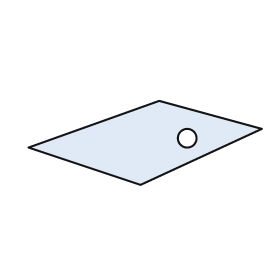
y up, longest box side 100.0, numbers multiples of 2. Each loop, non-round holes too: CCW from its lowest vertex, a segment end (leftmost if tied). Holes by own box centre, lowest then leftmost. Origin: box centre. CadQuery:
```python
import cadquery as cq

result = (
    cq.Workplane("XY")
    .moveTo(-2.0, -18.0)
    .lineTo(50.0, 6.0)
    .lineTo(6.0, 18.0)
    .lineTo(-50.0, -2.0)
    .close()
    .moveTo(18.0, 2.0)
    .circle(4.0)
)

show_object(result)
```